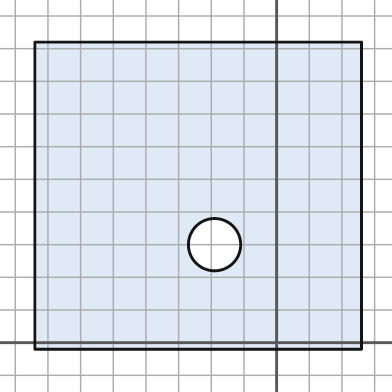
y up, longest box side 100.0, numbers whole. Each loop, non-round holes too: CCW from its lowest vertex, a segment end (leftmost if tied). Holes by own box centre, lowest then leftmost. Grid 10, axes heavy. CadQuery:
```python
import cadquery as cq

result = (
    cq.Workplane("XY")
    .moveTo(-74.0, -2.0)
    .lineTo(26.0, -2.0)
    .lineTo(26.0, 92.0)
    .lineTo(-74.0, 92.0)
    .close()
    .moveTo(-19.0, 30.0)
    .circle(8.0)
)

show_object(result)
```